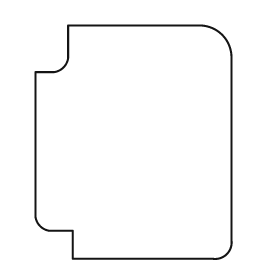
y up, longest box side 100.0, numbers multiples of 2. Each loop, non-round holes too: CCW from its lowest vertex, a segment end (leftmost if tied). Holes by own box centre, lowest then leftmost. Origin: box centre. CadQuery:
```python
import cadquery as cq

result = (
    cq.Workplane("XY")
    .moveTo(-26.0, -50.0)
    .lineTo(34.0, -50.0)
    .threePointArc((40.0, -48.0), (42.0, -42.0))
    .lineTo(42.0, 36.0)
    .threePointArc((38.0, 46.0), (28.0, 50.0))
    .lineTo(-28.0, 50.0)
    .lineTo(-28.0, 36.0)
    .threePointArc((-30.0, 32.0), (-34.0, 30.0))
    .lineTo(-42.0, 30.0)
    .lineTo(-42.0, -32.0)
    .threePointArc((-40.0, -36.0), (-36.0, -38.0))
    .lineTo(-26.0, -38.0)
    .close()
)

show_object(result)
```